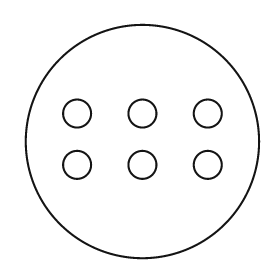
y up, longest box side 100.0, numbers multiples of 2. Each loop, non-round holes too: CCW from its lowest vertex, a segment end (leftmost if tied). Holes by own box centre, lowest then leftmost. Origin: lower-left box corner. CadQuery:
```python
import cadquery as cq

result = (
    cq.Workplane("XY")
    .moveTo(50.0, 50.0)
    .circle(50.0)
    .moveTo(22.0, 40.0)
    .circle(6.0)
    .moveTo(50.0, 40.0)
    .circle(6.0)
    .moveTo(78.0, 40.0)
    .circle(6.0)
    .moveTo(22.0, 62.0)
    .circle(6.0)
    .moveTo(50.0, 62.0)
    .circle(6.0)
    .moveTo(78.0, 62.0)
    .circle(6.0)
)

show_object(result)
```